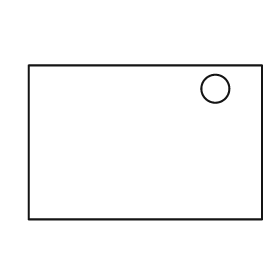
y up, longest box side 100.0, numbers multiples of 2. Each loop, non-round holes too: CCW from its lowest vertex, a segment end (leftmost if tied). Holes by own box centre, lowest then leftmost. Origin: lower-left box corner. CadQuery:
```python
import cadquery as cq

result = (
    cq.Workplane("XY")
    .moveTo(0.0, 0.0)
    .lineTo(100.0, 0.0)
    .lineTo(100.0, 66.0)
    .lineTo(0.0, 66.0)
    .close()
    .moveTo(80.0, 56.0)
    .circle(6.0)
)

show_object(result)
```